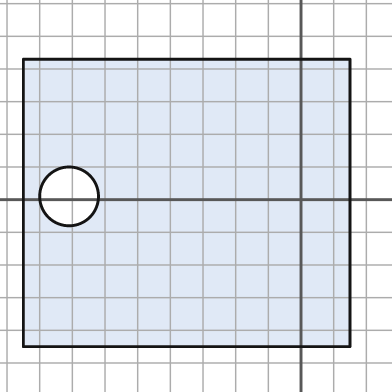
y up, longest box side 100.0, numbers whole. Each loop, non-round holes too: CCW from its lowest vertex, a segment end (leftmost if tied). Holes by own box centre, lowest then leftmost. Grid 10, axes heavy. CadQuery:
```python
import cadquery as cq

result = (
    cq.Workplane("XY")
    .moveTo(-85.0, -45.0)
    .lineTo(15.0, -45.0)
    .lineTo(15.0, 43.0)
    .lineTo(-85.0, 43.0)
    .close()
    .moveTo(-71.0, 1.0)
    .circle(9.0)
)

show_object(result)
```